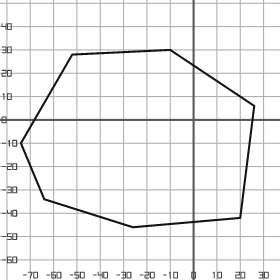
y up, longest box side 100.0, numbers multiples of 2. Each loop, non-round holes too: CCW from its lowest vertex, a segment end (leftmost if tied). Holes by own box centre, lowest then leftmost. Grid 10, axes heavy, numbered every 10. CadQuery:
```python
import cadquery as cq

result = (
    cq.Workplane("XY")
    .moveTo(-26.0, -46.0)
    .lineTo(20.0, -42.0)
    .lineTo(26.0, 6.0)
    .lineTo(-10.0, 30.0)
    .lineTo(-52.0, 28.0)
    .lineTo(-74.0, -10.0)
    .lineTo(-64.0, -34.0)
    .close()
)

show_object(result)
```